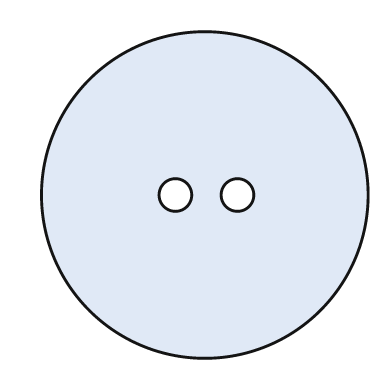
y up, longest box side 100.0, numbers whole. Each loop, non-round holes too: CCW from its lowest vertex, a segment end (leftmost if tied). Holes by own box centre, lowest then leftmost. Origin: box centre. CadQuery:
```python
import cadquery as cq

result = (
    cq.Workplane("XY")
    .moveTo(0.0, 0.0)
    .circle(50.0)
    .moveTo(-9.0, 0.0)
    .circle(5.0)
    .moveTo(10.0, 0.0)
    .circle(5.0)
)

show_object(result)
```